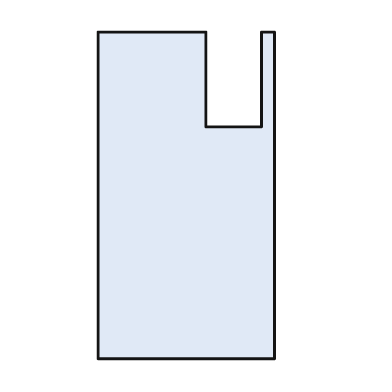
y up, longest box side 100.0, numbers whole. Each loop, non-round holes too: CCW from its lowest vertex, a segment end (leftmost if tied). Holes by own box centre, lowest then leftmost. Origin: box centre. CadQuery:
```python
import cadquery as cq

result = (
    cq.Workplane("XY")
    .moveTo(-27.0, -50.0)
    .lineTo(27.0, -50.0)
    .lineTo(27.0, 50.0)
    .lineTo(23.0, 50.0)
    .lineTo(23.0, 21.0)
    .lineTo(6.0, 21.0)
    .lineTo(6.0, 50.0)
    .lineTo(-27.0, 50.0)
    .close()
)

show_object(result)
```